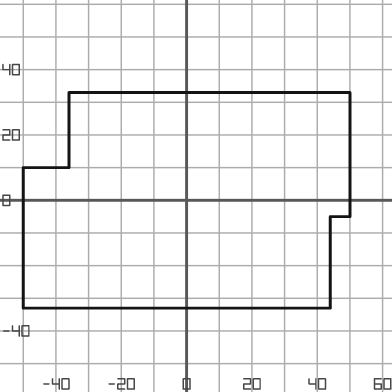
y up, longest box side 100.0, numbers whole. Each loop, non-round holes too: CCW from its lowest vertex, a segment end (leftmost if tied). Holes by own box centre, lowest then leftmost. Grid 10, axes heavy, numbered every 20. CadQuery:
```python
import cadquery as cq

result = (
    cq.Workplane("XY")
    .moveTo(-50.0, -33.0)
    .lineTo(44.0, -33.0)
    .lineTo(44.0, -5.0)
    .lineTo(50.0, -5.0)
    .lineTo(50.0, 33.0)
    .lineTo(-36.0, 33.0)
    .lineTo(-36.0, 10.0)
    .lineTo(-50.0, 10.0)
    .close()
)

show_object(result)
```